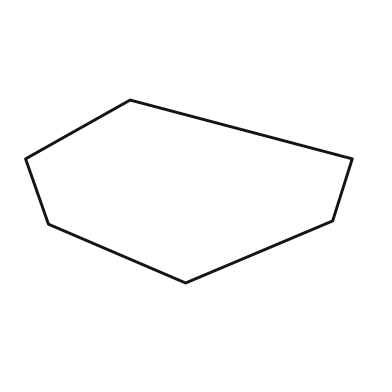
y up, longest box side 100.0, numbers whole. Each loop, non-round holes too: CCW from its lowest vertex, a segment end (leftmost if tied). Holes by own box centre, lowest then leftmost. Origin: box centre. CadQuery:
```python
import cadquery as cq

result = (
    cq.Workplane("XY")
    .moveTo(-1.0, -28.0)
    .lineTo(44.0, -9.0)
    .lineTo(50.0, 10.0)
    .lineTo(-18.0, 28.0)
    .lineTo(-50.0, 10.0)
    .lineTo(-43.0, -10.0)
    .close()
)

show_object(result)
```